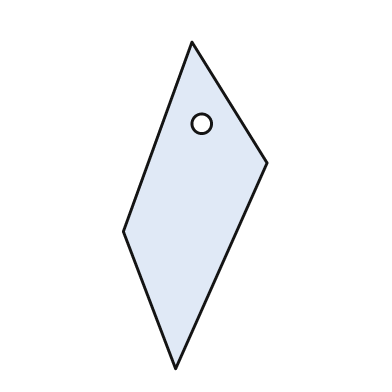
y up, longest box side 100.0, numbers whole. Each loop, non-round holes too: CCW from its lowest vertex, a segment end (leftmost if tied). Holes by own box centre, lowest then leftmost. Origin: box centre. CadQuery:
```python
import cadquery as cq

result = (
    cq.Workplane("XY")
    .moveTo(-6.0, -50.0)
    .lineTo(22.0, 13.0)
    .lineTo(-1.0, 50.0)
    .lineTo(-22.0, -8.0)
    .close()
    .moveTo(2.0, 25.0)
    .circle(3.0)
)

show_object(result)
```